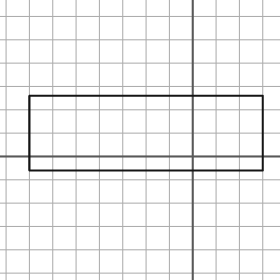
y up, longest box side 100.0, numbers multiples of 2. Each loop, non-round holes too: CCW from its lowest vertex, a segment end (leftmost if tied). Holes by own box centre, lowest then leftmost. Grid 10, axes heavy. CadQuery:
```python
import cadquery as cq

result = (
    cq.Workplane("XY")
    .moveTo(-70.0, -6.0)
    .lineTo(30.0, -6.0)
    .lineTo(30.0, 26.0)
    .lineTo(-70.0, 26.0)
    .close()
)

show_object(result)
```